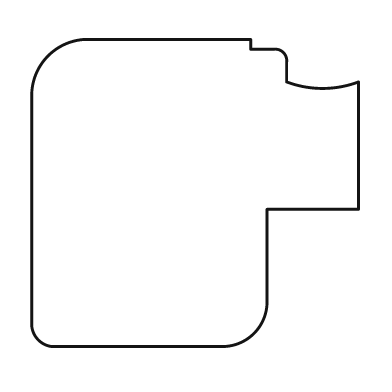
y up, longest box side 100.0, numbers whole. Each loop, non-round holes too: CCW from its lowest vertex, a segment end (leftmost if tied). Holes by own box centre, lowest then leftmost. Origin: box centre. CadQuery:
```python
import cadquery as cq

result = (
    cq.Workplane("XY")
    .moveTo(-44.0, -47.0)
    .lineTo(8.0, -47.0)
    .threePointArc((18.0, -43.0), (22.0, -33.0))
    .lineTo(22.0, -5.0)
    .lineTo(50.0, -5.0)
    .lineTo(50.0, 34.0)
    .threePointArc((39.0, 32.0), (28.0, 34.0))
    .lineTo(28.0, 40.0)
    .threePointArc((27.0, 43.0), (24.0, 44.0))
    .lineTo(17.0, 44.0)
    .lineTo(17.0, 47.0)
    .lineTo(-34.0, 47.0)
    .threePointArc((-45.0, 42.0), (-50.0, 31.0))
    .lineTo(-50.0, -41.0)
    .threePointArc((-48.0, -45.0), (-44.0, -47.0))
    .close()
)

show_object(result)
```